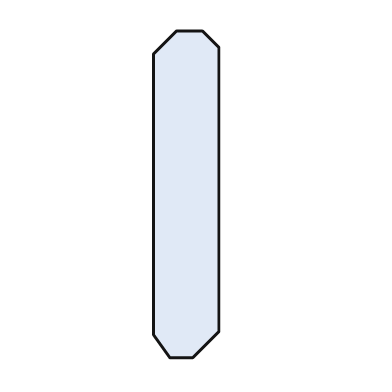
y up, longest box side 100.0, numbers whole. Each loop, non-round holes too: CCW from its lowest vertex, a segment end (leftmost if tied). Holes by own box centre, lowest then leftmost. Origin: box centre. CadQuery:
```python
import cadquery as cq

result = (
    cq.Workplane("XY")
    .moveTo(-5.0, -50.0)
    .lineTo(2.0, -50.0)
    .lineTo(10.0, -42.0)
    .lineTo(10.0, 45.0)
    .lineTo(5.0, 50.0)
    .lineTo(-3.0, 50.0)
    .lineTo(-10.0, 43.0)
    .lineTo(-10.0, -43.0)
    .close()
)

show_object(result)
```